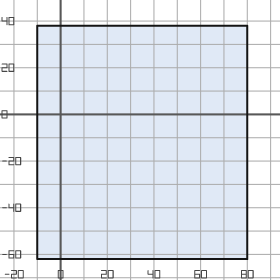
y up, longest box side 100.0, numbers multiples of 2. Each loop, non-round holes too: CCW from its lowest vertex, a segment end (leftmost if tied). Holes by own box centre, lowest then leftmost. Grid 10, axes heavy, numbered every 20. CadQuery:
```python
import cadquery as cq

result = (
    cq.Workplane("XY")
    .moveTo(-10.0, -62.0)
    .lineTo(80.0, -62.0)
    .lineTo(80.0, 38.0)
    .lineTo(-10.0, 38.0)
    .close()
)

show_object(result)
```